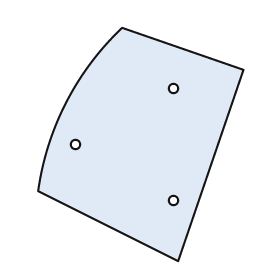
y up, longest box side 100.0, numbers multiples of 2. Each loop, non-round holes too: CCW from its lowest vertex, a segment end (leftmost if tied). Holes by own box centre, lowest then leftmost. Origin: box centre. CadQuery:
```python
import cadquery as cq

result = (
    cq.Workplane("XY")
    .moveTo(16.0, -50.0)
    .lineTo(44.0, 32.0)
    .lineTo(-8.0, 50.0)
    .threePointArc((-32.0, 18.0), (-44.0, -20.0))
    .close()
    .moveTo(14.0, -24.0)
    .circle(2.0)
    .moveTo(-28.0, 0.0)
    .circle(2.0)
    .moveTo(14.0, 24.0)
    .circle(2.0)
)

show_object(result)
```